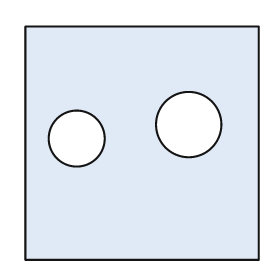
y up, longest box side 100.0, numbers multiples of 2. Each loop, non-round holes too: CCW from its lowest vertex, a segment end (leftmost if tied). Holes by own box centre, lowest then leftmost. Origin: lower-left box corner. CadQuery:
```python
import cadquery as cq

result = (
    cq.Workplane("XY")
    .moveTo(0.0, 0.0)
    .lineTo(100.0, 0.0)
    .lineTo(100.0, 100.0)
    .lineTo(0.0, 100.0)
    .close()
    .moveTo(22.0, 52.0)
    .circle(12.0)
    .moveTo(70.0, 58.0)
    .circle(14.0)
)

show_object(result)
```